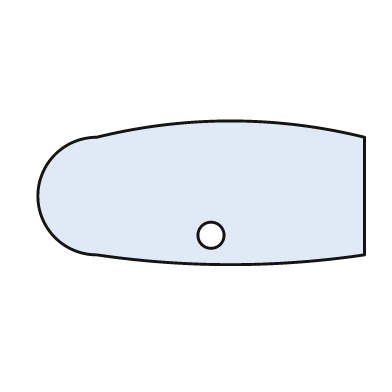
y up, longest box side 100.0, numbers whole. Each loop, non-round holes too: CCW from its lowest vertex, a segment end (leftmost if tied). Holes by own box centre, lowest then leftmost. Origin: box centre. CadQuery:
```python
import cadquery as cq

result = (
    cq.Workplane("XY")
    .moveTo(-32.0, -19.0)
    .threePointArc((9.0, -22.0), (50.0, -19.0))
    .lineTo(50.0, 17.0)
    .threePointArc((9.0, 22.0), (-32.0, 17.0))
    .threePointArc((-50.0, -1.0), (-32.0, -19.0))
    .close()
    .moveTo(3.0, -13.0)
    .circle(4.0)
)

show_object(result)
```